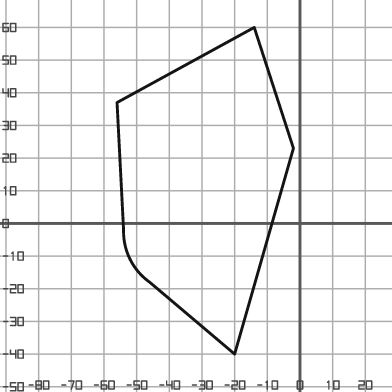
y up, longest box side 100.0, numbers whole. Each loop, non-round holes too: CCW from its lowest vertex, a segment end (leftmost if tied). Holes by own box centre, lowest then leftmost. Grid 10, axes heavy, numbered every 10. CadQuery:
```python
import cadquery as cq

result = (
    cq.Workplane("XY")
    .moveTo(-20.0, -40.0)
    .lineTo(-2.0, 23.0)
    .lineTo(-14.0, 60.0)
    .lineTo(-56.0, 37.0)
    .lineTo(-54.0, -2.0)
    .threePointArc((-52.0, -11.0), (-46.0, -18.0))
    .close()
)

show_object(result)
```